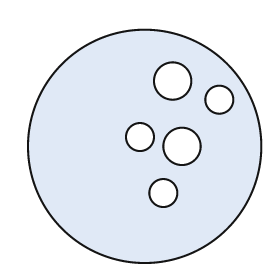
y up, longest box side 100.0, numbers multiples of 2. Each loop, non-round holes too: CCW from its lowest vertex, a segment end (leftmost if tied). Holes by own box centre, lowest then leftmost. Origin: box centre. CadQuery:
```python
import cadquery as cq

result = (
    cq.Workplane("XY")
    .moveTo(0.0, 0.0)
    .circle(50.0)
    .moveTo(8.0, -20.0)
    .circle(6.0)
    .moveTo(16.0, 0.0)
    .circle(8.0)
    .moveTo(-2.0, 4.0)
    .circle(6.0)
    .moveTo(32.0, 20.0)
    .circle(6.0)
    .moveTo(12.0, 28.0)
    .circle(8.0)
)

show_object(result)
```